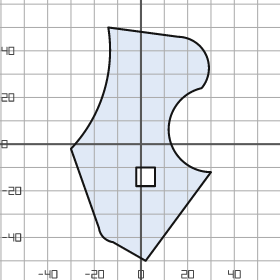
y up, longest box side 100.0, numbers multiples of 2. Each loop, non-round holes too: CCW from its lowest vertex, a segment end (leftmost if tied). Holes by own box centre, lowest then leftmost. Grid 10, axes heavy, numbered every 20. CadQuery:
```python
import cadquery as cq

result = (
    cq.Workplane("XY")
    .moveTo(2.0, -50.0)
    .lineTo(30.0, -12.0)
    .threePointArc((12.0, 4.0), (26.0, 24.0))
    .threePointArc((28.0, 38.0), (16.0, 46.0))
    .lineTo(-14.0, 50.0)
    .threePointArc((-16.0, 22.0), (-30.0, -2.0))
    .lineTo(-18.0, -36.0)
    .threePointArc((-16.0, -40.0), (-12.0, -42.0))
    .close()
    .moveTo(-2.0, -18.0)
    .lineTo(6.0, -18.0)
    .lineTo(6.0, -10.0)
    .lineTo(-2.0, -10.0)
    .close()
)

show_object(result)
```